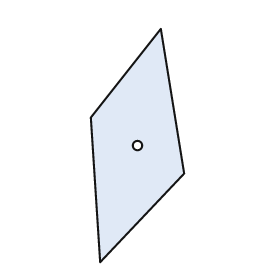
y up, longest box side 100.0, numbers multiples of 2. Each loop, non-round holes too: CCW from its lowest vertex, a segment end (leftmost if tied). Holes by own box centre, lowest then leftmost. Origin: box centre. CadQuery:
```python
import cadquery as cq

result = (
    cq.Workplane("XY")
    .moveTo(-16.0, -50.0)
    .lineTo(20.0, -12.0)
    .lineTo(10.0, 50.0)
    .lineTo(-20.0, 12.0)
    .close()
    .moveTo(0.0, 0.0)
    .circle(2.0)
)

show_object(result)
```